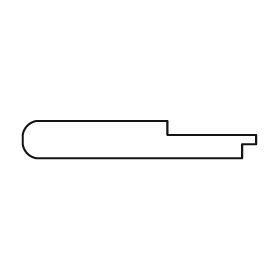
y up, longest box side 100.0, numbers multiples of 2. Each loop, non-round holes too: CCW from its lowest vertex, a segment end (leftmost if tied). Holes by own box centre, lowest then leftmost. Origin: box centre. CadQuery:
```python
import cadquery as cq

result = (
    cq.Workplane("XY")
    .moveTo(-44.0, -8.0)
    .lineTo(44.0, -8.0)
    .lineTo(44.0, -2.0)
    .lineTo(50.0, -2.0)
    .lineTo(50.0, 2.0)
    .lineTo(12.0, 2.0)
    .lineTo(12.0, 8.0)
    .lineTo(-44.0, 8.0)
    .threePointArc((-48.0, 6.0), (-50.0, 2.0))
    .lineTo(-50.0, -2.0)
    .threePointArc((-48.0, -6.0), (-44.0, -8.0))
    .close()
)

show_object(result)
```